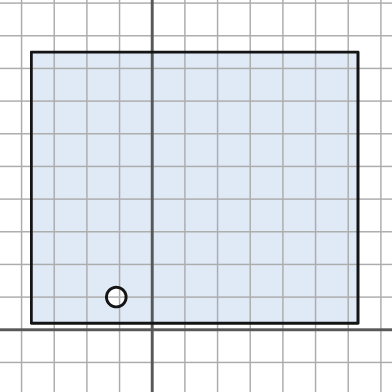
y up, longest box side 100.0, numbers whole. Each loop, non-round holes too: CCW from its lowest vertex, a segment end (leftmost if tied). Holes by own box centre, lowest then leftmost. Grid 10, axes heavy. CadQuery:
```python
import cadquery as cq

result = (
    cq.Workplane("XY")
    .moveTo(-37.0, 2.0)
    .lineTo(63.0, 2.0)
    .lineTo(63.0, 85.0)
    .lineTo(-37.0, 85.0)
    .close()
    .moveTo(-11.0, 10.0)
    .circle(3.0)
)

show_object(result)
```